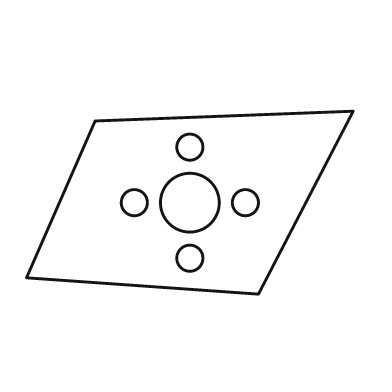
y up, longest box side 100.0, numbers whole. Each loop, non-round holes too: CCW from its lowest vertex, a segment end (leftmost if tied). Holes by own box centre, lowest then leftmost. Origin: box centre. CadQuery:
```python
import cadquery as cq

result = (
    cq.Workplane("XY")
    .moveTo(21.0, -28.0)
    .lineTo(50.0, 28.0)
    .lineTo(-29.0, 25.0)
    .lineTo(-50.0, -23.0)
    .close()
    .moveTo(0.0, -17.0)
    .circle(4.0)
    .moveTo(-17.0, 0.0)
    .circle(4.0)
    .moveTo(0.0, 0.0)
    .circle(9.0)
    .moveTo(17.0, 0.0)
    .circle(4.0)
    .moveTo(0.0, 17.0)
    .circle(4.0)
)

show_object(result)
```